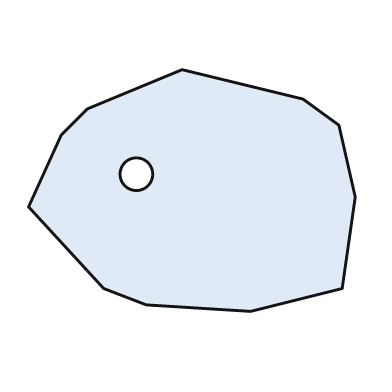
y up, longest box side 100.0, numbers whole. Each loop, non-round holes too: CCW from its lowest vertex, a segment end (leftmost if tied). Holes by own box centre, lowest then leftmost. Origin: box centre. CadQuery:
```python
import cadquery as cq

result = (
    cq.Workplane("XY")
    .moveTo(18.0, -37.0)
    .lineTo(46.0, -30.0)
    .lineTo(50.0, -2.0)
    .lineTo(45.0, 20.0)
    .lineTo(34.0, 28.0)
    .lineTo(-3.0, 37.0)
    .lineTo(-32.0, 25.0)
    .lineTo(-40.0, 17.0)
    .lineTo(-50.0, -5.0)
    .lineTo(-27.0, -30.0)
    .lineTo(-14.0, -35.0)
    .close()
    .moveTo(-17.0, 5.0)
    .circle(5.0)
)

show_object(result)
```